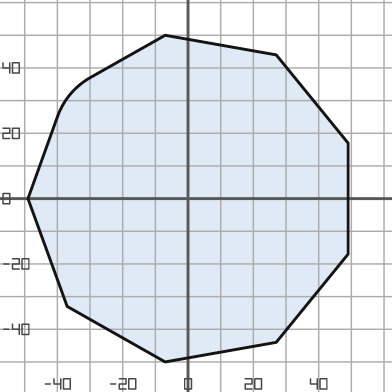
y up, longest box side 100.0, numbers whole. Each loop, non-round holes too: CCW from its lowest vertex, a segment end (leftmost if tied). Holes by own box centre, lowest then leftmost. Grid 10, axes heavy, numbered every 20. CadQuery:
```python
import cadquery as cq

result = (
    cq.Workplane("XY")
    .moveTo(-7.0, -50.0)
    .lineTo(27.0, -44.0)
    .lineTo(49.0, -17.0)
    .lineTo(49.0, 17.0)
    .lineTo(27.0, 44.0)
    .lineTo(-7.0, 50.0)
    .lineTo(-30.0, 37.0)
    .threePointArc((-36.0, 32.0), (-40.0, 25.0))
    .lineTo(-49.0, 0.0)
    .lineTo(-37.0, -33.0)
    .close()
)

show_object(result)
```